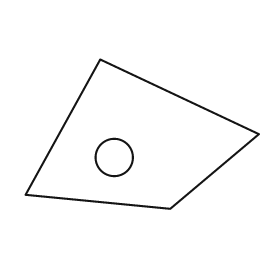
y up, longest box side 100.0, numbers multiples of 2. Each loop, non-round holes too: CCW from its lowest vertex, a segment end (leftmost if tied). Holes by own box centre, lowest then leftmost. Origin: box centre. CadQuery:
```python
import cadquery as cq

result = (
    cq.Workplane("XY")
    .moveTo(12.0, -32.0)
    .lineTo(50.0, 0.0)
    .lineTo(-18.0, 32.0)
    .lineTo(-50.0, -26.0)
    .close()
    .moveTo(-12.0, -10.0)
    .circle(8.0)
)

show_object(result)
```